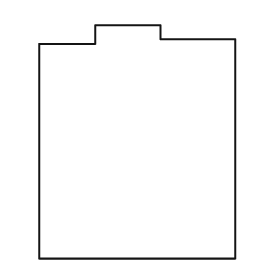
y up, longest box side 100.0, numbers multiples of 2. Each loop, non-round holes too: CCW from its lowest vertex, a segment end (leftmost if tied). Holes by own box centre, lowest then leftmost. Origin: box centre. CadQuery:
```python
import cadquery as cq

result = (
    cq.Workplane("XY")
    .moveTo(-42.0, -50.0)
    .lineTo(42.0, -50.0)
    .lineTo(42.0, 44.0)
    .lineTo(10.0, 44.0)
    .lineTo(10.0, 50.0)
    .lineTo(-18.0, 50.0)
    .lineTo(-18.0, 42.0)
    .lineTo(-42.0, 42.0)
    .close()
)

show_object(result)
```